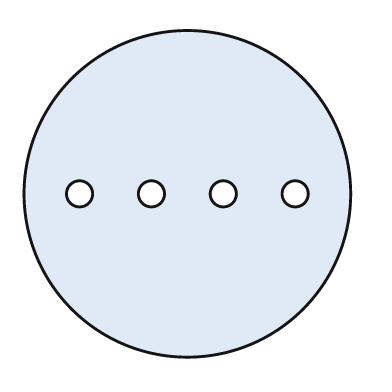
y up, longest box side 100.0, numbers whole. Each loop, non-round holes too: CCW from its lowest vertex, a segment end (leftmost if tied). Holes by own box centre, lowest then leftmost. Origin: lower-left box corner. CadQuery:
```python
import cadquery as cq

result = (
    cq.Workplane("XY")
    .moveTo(50.0, 50.0)
    .circle(50.0)
    .moveTo(17.0, 50.0)
    .circle(4.0)
    .moveTo(39.0, 50.0)
    .circle(4.0)
    .moveTo(61.0, 50.0)
    .circle(4.0)
    .moveTo(83.0, 50.0)
    .circle(4.0)
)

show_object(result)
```